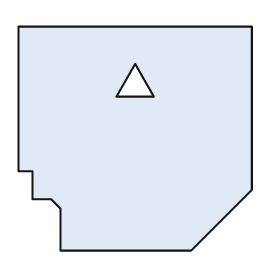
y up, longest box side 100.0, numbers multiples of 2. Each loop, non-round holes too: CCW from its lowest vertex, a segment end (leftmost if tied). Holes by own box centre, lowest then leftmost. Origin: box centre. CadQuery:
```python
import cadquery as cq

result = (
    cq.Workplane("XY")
    .moveTo(-32.0, -48.0)
    .lineTo(24.0, -48.0)
    .lineTo(50.0, -22.0)
    .lineTo(50.0, 48.0)
    .lineTo(-50.0, 48.0)
    .lineTo(-50.0, -14.0)
    .lineTo(-44.0, -14.0)
    .lineTo(-44.0, -26.0)
    .lineTo(-36.0, -26.0)
    .lineTo(-32.0, -30.0)
    .close()
    .moveTo(-8.0, 18.0)
    .lineTo(8.0, 18.0)
    .lineTo(0.0, 32.0)
    .close()
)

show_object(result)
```